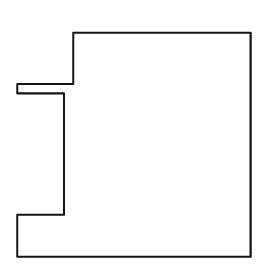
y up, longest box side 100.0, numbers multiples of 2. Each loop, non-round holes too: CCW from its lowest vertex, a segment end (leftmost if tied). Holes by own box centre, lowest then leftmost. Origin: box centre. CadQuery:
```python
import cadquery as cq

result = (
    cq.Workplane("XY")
    .moveTo(-50.0, -48.0)
    .lineTo(50.0, -48.0)
    .lineTo(50.0, 48.0)
    .lineTo(-26.0, 48.0)
    .lineTo(-26.0, 26.0)
    .lineTo(-50.0, 26.0)
    .lineTo(-50.0, 22.0)
    .lineTo(-30.0, 22.0)
    .lineTo(-30.0, -30.0)
    .lineTo(-50.0, -30.0)
    .close()
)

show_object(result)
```